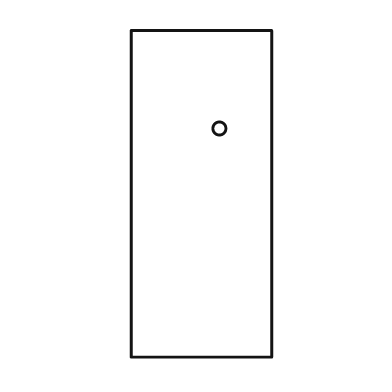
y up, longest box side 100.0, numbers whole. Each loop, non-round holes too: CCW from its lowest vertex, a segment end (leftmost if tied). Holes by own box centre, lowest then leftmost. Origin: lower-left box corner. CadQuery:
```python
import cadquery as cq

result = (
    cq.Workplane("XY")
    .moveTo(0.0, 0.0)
    .lineTo(43.0, 0.0)
    .lineTo(43.0, 100.0)
    .lineTo(0.0, 100.0)
    .close()
    .moveTo(27.0, 70.0)
    .circle(2.0)
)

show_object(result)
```